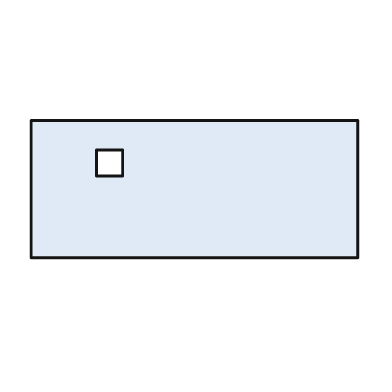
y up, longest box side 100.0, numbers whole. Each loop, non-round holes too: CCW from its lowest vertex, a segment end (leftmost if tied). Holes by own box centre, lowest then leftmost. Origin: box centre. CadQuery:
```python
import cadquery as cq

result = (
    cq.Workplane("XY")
    .moveTo(-50.0, -21.0)
    .lineTo(50.0, -21.0)
    .lineTo(50.0, 21.0)
    .lineTo(-50.0, 21.0)
    .close()
    .moveTo(-30.0, 4.0)
    .lineTo(-22.0, 4.0)
    .lineTo(-22.0, 12.0)
    .lineTo(-30.0, 12.0)
    .close()
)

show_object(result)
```